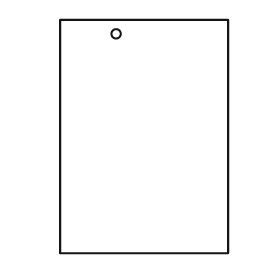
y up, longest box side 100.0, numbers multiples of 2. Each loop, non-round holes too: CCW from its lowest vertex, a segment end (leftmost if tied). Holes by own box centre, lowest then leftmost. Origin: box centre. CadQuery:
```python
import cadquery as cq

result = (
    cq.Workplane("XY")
    .moveTo(-36.0, -50.0)
    .lineTo(36.0, -50.0)
    .lineTo(36.0, 50.0)
    .lineTo(-36.0, 50.0)
    .close()
    .moveTo(-12.0, 44.0)
    .circle(2.0)
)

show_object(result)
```